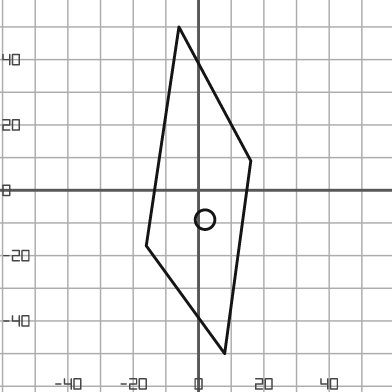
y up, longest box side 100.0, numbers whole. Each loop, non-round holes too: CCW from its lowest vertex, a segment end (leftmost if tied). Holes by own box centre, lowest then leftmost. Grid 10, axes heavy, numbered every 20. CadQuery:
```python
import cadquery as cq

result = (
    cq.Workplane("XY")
    .moveTo(8.0, -50.0)
    .lineTo(16.0, 9.0)
    .lineTo(-6.0, 50.0)
    .lineTo(-16.0, -17.0)
    .close()
    .moveTo(2.0, -9.0)
    .circle(3.0)
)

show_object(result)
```